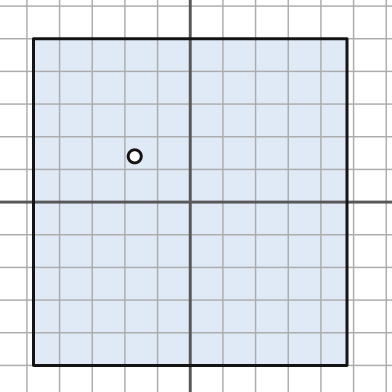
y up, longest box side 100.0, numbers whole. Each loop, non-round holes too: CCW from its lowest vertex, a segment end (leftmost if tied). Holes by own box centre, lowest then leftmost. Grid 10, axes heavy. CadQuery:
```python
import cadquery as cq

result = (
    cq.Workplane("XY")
    .moveTo(-48.0, -50.0)
    .lineTo(48.0, -50.0)
    .lineTo(48.0, 50.0)
    .lineTo(-48.0, 50.0)
    .close()
    .moveTo(-17.0, 14.0)
    .circle(2.0)
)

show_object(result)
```